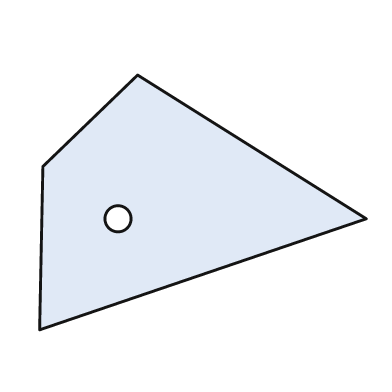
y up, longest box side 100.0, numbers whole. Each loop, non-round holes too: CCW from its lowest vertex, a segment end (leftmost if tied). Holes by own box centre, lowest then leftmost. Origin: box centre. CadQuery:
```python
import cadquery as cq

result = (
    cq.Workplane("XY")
    .moveTo(-50.0, -39.0)
    .lineTo(50.0, -5.0)
    .lineTo(-20.0, 39.0)
    .lineTo(-49.0, 11.0)
    .close()
    .moveTo(-26.0, -5.0)
    .circle(4.0)
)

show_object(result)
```